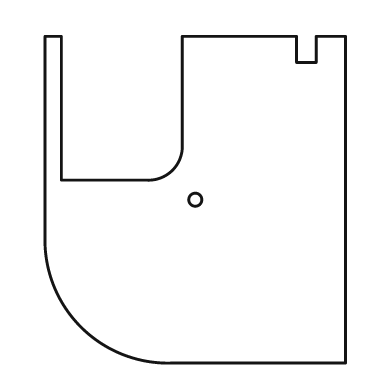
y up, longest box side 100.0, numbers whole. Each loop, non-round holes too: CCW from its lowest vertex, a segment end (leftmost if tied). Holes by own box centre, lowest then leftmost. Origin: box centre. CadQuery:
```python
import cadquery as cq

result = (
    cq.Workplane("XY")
    .moveTo(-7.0, -50.0)
    .lineTo(46.0, -50.0)
    .lineTo(46.0, 50.0)
    .lineTo(37.0, 50.0)
    .lineTo(37.0, 42.0)
    .lineTo(31.0, 42.0)
    .lineTo(31.0, 50.0)
    .lineTo(-4.0, 50.0)
    .lineTo(-4.0, 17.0)
    .threePointArc((-7.0, 9.0), (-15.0, 6.0))
    .lineTo(-41.0, 6.0)
    .lineTo(-41.0, 50.0)
    .lineTo(-46.0, 50.0)
    .lineTo(-46.0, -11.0)
    .threePointArc((-35.0, -39.0), (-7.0, -50.0))
    .close()
    .moveTo(0.0, 0.0)
    .circle(2.0)
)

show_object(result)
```